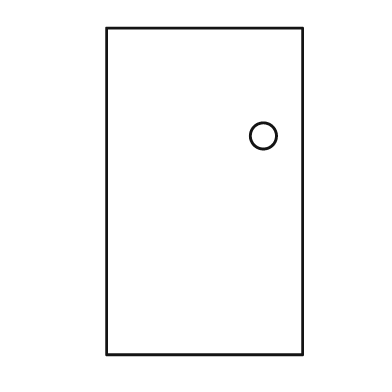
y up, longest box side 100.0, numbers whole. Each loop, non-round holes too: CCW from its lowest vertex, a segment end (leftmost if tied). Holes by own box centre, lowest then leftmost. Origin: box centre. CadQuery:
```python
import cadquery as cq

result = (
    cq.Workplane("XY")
    .moveTo(-30.0, -50.0)
    .lineTo(30.0, -50.0)
    .lineTo(30.0, 50.0)
    .lineTo(-30.0, 50.0)
    .close()
    .moveTo(18.0, 17.0)
    .circle(4.0)
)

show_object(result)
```